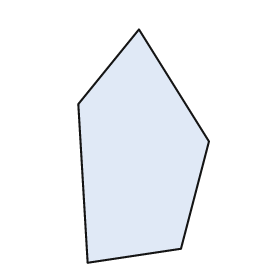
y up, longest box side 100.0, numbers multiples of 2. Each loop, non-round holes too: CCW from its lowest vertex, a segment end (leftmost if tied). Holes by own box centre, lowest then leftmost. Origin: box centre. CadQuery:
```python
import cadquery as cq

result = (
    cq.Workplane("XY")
    .moveTo(-24.0, -50.0)
    .lineTo(16.0, -44.0)
    .lineTo(28.0, 2.0)
    .lineTo(-2.0, 50.0)
    .lineTo(-28.0, 18.0)
    .close()
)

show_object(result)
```